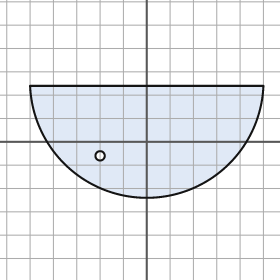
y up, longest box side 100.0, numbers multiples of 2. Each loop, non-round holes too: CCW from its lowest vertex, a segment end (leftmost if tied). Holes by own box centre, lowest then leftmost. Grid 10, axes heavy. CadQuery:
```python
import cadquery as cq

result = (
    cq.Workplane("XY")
    .moveTo(-50.0, 24.0)
    .threePointArc((0.0, -24.0), (50.0, 24.0))
    .close()
    .moveTo(-20.0, -6.0)
    .circle(2.0)
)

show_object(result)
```